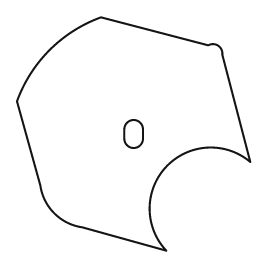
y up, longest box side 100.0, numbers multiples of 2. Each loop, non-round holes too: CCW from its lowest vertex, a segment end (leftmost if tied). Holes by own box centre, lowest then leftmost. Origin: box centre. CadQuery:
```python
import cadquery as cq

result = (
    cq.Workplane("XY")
    .moveTo(14.0, -50.0)
    .threePointArc((14.0, -14.0), (50.0, -12.0))
    .lineTo(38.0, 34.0)
    .threePointArc((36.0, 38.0), (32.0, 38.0))
    .lineTo(-14.0, 50.0)
    .threePointArc((-36.0, 36.0), (-50.0, 14.0))
    .lineTo(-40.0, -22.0)
    .threePointArc((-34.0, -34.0), (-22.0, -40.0))
    .close()
    .moveTo(-4.0, -2.0)
    .threePointArc((0.0, -6.0), (4.0, -2.0))
    .lineTo(4.0, 2.0)
    .threePointArc((0.0, 6.0), (-4.0, 2.0))
    .close()
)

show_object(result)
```